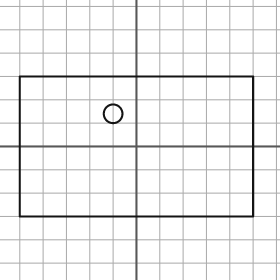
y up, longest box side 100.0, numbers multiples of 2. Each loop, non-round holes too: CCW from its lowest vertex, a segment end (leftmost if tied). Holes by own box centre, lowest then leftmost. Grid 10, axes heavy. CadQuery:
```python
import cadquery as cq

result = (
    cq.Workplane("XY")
    .moveTo(-50.0, -30.0)
    .lineTo(50.0, -30.0)
    .lineTo(50.0, 30.0)
    .lineTo(-50.0, 30.0)
    .close()
    .moveTo(-10.0, 14.0)
    .circle(4.0)
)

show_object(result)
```